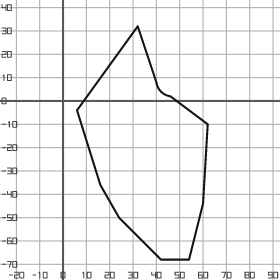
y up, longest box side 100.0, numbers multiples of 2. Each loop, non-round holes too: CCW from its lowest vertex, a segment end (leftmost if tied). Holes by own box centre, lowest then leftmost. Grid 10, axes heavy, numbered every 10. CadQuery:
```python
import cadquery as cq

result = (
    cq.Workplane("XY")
    .moveTo(42.0, -68.0)
    .lineTo(54.0, -68.0)
    .lineTo(60.0, -44.0)
    .lineTo(62.0, -10.0)
    .lineTo(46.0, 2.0)
    .threePointArc((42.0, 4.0), (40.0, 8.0))
    .lineTo(32.0, 32.0)
    .lineTo(6.0, -4.0)
    .lineTo(16.0, -36.0)
    .lineTo(24.0, -50.0)
    .close()
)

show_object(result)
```